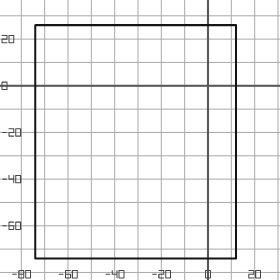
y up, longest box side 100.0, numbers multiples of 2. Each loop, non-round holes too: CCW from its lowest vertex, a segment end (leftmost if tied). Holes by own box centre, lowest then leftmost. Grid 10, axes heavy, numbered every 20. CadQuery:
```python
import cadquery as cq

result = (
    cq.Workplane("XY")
    .moveTo(-74.0, -74.0)
    .lineTo(12.0, -74.0)
    .lineTo(12.0, 26.0)
    .lineTo(-74.0, 26.0)
    .close()
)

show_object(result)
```